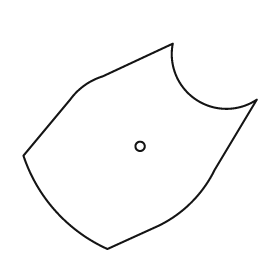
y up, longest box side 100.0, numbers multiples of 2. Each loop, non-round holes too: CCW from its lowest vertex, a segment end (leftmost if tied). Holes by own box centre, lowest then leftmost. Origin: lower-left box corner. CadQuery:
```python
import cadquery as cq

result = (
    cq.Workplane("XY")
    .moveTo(36.0, 0.0)
    .lineTo(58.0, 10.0)
    .threePointArc((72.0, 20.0), (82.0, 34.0))
    .lineTo(100.0, 64.0)
    .threePointArc((74.0, 64.0), (64.0, 88.0))
    .lineTo(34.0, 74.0)
    .threePointArc((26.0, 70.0), (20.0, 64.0))
    .lineTo(0.0, 40.0)
    .threePointArc((14.0, 16.0), (36.0, 0.0))
    .close()
    .moveTo(50.0, 44.0)
    .circle(2.0)
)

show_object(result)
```